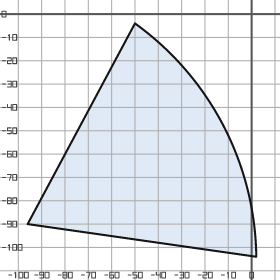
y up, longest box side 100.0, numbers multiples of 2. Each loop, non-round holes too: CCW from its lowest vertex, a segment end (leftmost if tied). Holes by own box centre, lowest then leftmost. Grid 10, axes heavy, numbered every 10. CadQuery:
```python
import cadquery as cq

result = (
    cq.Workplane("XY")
    .moveTo(2.0, -104.0)
    .threePointArc((-12.0, -48.0), (-50.0, -4.0))
    .lineTo(-96.0, -90.0)
    .close()
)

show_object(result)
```